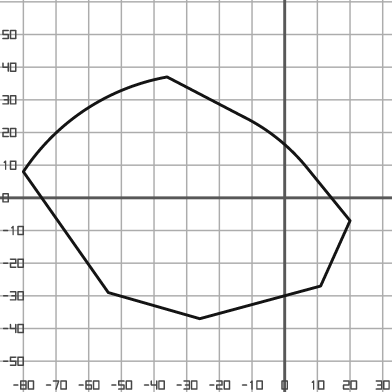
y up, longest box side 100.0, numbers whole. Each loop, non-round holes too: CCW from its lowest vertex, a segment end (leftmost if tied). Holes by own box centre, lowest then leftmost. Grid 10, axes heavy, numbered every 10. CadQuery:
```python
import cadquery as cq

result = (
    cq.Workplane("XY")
    .moveTo(-26.0, -37.0)
    .lineTo(11.0, -27.0)
    .lineTo(20.0, -7.0)
    .lineTo(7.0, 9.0)
    .threePointArc((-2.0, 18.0), (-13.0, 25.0))
    .lineTo(-36.0, 37.0)
    .threePointArc((-61.0, 27.0), (-80.0, 8.0))
    .lineTo(-54.0, -29.0)
    .close()
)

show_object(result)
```